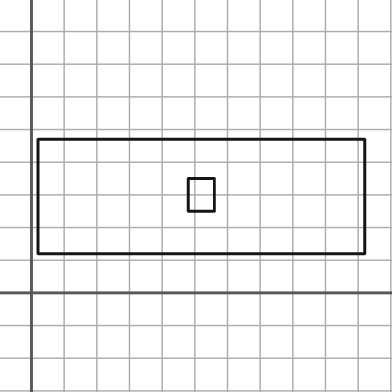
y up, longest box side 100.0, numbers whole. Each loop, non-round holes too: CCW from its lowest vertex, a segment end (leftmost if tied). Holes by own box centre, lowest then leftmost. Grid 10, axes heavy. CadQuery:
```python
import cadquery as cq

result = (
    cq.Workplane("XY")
    .moveTo(2.0, 12.0)
    .lineTo(102.0, 12.0)
    .lineTo(102.0, 47.0)
    .lineTo(2.0, 47.0)
    .close()
    .moveTo(48.0, 25.0)
    .lineTo(56.0, 25.0)
    .lineTo(56.0, 35.0)
    .lineTo(48.0, 35.0)
    .close()
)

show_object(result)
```